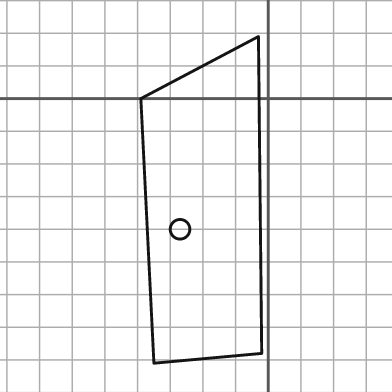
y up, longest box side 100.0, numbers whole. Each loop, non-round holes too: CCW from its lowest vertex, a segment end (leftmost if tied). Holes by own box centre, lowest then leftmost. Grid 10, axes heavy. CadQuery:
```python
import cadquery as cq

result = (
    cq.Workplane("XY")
    .moveTo(-35.0, -81.0)
    .lineTo(-2.0, -78.0)
    .lineTo(-3.0, 19.0)
    .lineTo(-39.0, 0.0)
    .close()
    .moveTo(-27.0, -40.0)
    .circle(3.0)
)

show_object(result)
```